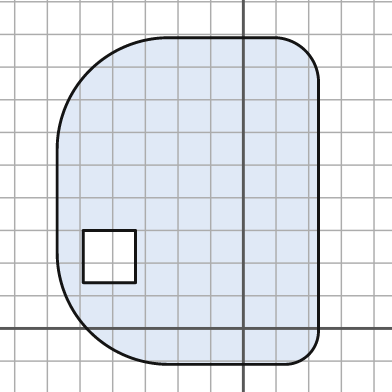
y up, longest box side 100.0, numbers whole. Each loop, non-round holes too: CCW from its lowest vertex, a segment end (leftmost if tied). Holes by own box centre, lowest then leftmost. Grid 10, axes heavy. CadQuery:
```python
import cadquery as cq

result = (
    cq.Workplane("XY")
    .moveTo(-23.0, -11.0)
    .lineTo(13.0, -11.0)
    .threePointArc((20.0, -8.0), (23.0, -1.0))
    .lineTo(23.0, 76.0)
    .threePointArc((19.0, 85.0), (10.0, 89.0))
    .lineTo(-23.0, 89.0)
    .threePointArc((-47.0, 79.0), (-57.0, 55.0))
    .lineTo(-57.0, 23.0)
    .threePointArc((-47.0, -1.0), (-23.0, -11.0))
    .close()
    .moveTo(-49.0, 14.0)
    .lineTo(-33.0, 14.0)
    .lineTo(-33.0, 30.0)
    .lineTo(-49.0, 30.0)
    .close()
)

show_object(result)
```